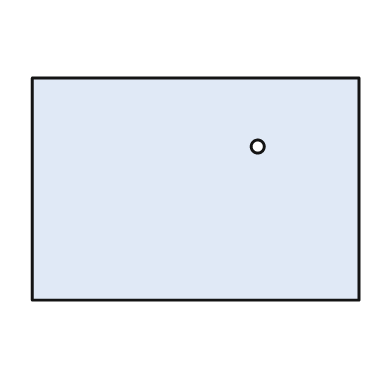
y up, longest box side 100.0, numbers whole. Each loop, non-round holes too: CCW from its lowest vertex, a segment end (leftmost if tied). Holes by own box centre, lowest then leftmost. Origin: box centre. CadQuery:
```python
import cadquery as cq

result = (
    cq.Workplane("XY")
    .moveTo(-50.0, -34.0)
    .lineTo(50.0, -34.0)
    .lineTo(50.0, 34.0)
    .lineTo(-50.0, 34.0)
    .close()
    .moveTo(19.0, 13.0)
    .circle(2.0)
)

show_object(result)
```